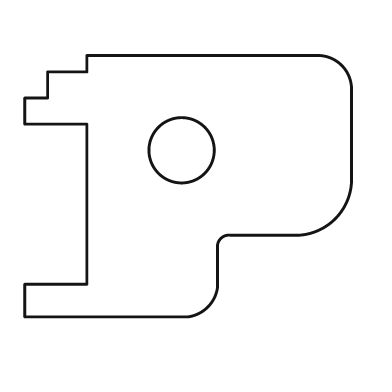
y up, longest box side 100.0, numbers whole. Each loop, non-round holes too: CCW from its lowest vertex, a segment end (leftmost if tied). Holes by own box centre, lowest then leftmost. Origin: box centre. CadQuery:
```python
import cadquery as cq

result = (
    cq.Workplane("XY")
    .moveTo(-50.0, -40.0)
    .lineTo(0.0, -40.0)
    .threePointArc((6.0, -37.0), (9.0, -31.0))
    .lineTo(9.0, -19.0)
    .threePointArc((10.0, -16.0), (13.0, -15.0))
    .lineTo(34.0, -15.0)
    .threePointArc((45.0, -10.0), (50.0, 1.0))
    .lineTo(50.0, 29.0)
    .threePointArc((47.0, 37.0), (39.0, 40.0))
    .lineTo(-31.0, 40.0)
    .lineTo(-31.0, 35.0)
    .lineTo(-43.0, 35.0)
    .lineTo(-43.0, 27.0)
    .lineTo(-50.0, 27.0)
    .lineTo(-50.0, 19.0)
    .lineTo(-31.0, 19.0)
    .lineTo(-31.0, -30.0)
    .lineTo(-50.0, -30.0)
    .close()
    .moveTo(-2.0, 11.0)
    .circle(10.0)
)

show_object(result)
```